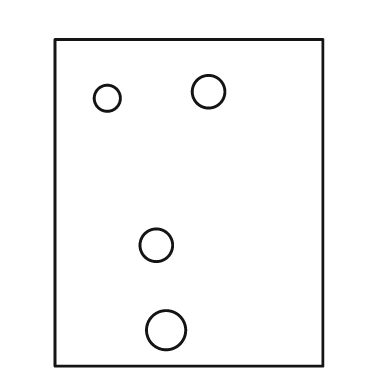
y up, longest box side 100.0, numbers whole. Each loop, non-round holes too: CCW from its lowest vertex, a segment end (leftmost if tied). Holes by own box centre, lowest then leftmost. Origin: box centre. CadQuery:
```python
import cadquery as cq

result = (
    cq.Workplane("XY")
    .moveTo(-41.0, -50.0)
    .lineTo(41.0, -50.0)
    .lineTo(41.0, 50.0)
    .lineTo(-41.0, 50.0)
    .close()
    .moveTo(-7.0, -39.0)
    .circle(6.0)
    .moveTo(-10.0, -13.0)
    .circle(5.0)
    .moveTo(-25.0, 32.0)
    .circle(4.0)
    .moveTo(6.0, 34.0)
    .circle(5.0)
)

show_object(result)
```